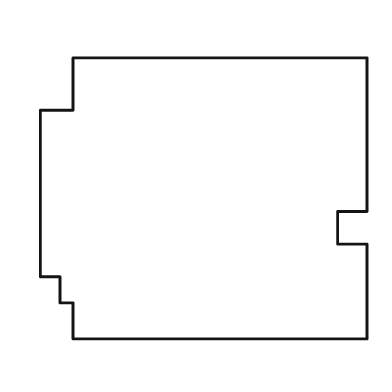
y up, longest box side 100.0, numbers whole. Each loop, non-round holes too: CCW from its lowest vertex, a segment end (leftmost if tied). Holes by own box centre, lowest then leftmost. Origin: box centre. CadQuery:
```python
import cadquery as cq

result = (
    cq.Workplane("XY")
    .moveTo(-40.0, -43.0)
    .lineTo(50.0, -43.0)
    .lineTo(50.0, -14.0)
    .lineTo(41.0, -14.0)
    .lineTo(41.0, -4.0)
    .lineTo(50.0, -4.0)
    .lineTo(50.0, 43.0)
    .lineTo(-40.0, 43.0)
    .lineTo(-40.0, 27.0)
    .lineTo(-50.0, 27.0)
    .lineTo(-50.0, -24.0)
    .lineTo(-44.0, -24.0)
    .lineTo(-44.0, -32.0)
    .lineTo(-40.0, -32.0)
    .close()
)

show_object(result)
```